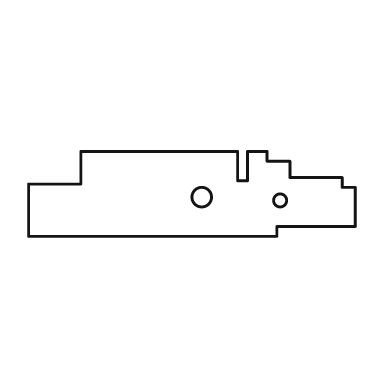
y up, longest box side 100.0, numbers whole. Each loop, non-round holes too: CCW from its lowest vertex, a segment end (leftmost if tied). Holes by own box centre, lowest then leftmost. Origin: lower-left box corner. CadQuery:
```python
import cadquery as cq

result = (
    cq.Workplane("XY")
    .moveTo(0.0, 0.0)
    .lineTo(76.0, 0.0)
    .lineTo(76.0, 3.0)
    .lineTo(100.0, 3.0)
    .lineTo(100.0, 15.0)
    .lineTo(96.0, 15.0)
    .lineTo(96.0, 18.0)
    .lineTo(80.0, 18.0)
    .lineTo(80.0, 23.0)
    .lineTo(73.0, 23.0)
    .lineTo(73.0, 26.0)
    .lineTo(67.0, 26.0)
    .lineTo(67.0, 17.0)
    .lineTo(64.0, 17.0)
    .lineTo(64.0, 26.0)
    .lineTo(16.0, 26.0)
    .lineTo(16.0, 16.0)
    .lineTo(0.0, 16.0)
    .close()
    .moveTo(77.0, 11.0)
    .circle(2.0)
    .moveTo(53.0, 12.0)
    .circle(3.0)
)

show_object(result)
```